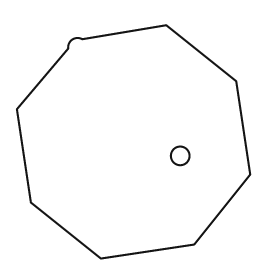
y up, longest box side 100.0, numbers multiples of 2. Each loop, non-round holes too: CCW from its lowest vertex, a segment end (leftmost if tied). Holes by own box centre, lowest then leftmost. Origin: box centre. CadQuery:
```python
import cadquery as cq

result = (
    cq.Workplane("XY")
    .moveTo(-14.0, -50.0)
    .lineTo(26.0, -44.0)
    .lineTo(50.0, -14.0)
    .lineTo(44.0, 26.0)
    .lineTo(14.0, 50.0)
    .lineTo(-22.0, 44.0)
    .threePointArc((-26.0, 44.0), (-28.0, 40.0))
    .lineTo(-50.0, 14.0)
    .lineTo(-44.0, -26.0)
    .close()
    .moveTo(20.0, -6.0)
    .circle(4.0)
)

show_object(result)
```